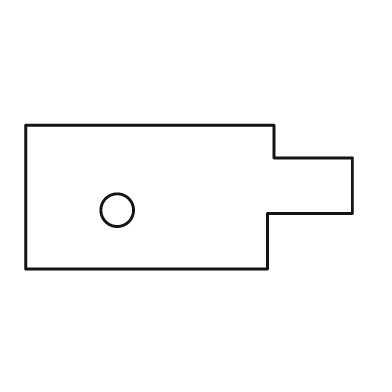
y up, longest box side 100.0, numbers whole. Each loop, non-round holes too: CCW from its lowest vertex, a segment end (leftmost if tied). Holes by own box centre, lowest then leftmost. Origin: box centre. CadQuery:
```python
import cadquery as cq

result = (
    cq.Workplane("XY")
    .moveTo(-50.0, -22.0)
    .lineTo(24.0, -22.0)
    .lineTo(24.0, -5.0)
    .lineTo(50.0, -5.0)
    .lineTo(50.0, 12.0)
    .lineTo(26.0, 12.0)
    .lineTo(26.0, 22.0)
    .lineTo(-50.0, 22.0)
    .close()
    .moveTo(-22.0, -4.0)
    .circle(5.0)
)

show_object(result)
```